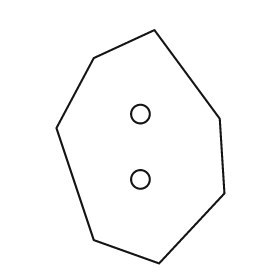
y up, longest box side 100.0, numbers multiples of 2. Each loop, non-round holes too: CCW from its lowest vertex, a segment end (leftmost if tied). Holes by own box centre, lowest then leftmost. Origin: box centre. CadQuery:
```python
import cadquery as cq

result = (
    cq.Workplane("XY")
    .moveTo(8.0, -50.0)
    .lineTo(36.0, -20.0)
    .lineTo(34.0, 12.0)
    .lineTo(6.0, 50.0)
    .lineTo(-20.0, 38.0)
    .lineTo(-36.0, 8.0)
    .lineTo(-20.0, -40.0)
    .close()
    .moveTo(0.0, -14.0)
    .circle(4.0)
    .moveTo(0.0, 14.0)
    .circle(4.0)
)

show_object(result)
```